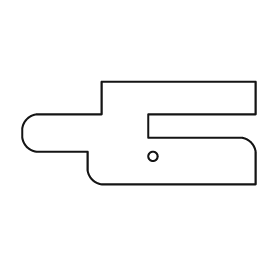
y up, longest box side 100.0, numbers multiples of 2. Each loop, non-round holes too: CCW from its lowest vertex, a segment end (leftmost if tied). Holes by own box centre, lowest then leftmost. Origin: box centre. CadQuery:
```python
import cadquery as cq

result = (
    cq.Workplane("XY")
    .moveTo(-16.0, -22.0)
    .lineTo(50.0, -22.0)
    .lineTo(50.0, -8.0)
    .threePointArc((48.0, -4.0), (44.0, -2.0))
    .lineTo(4.0, -2.0)
    .lineTo(4.0, 8.0)
    .lineTo(50.0, 8.0)
    .lineTo(50.0, 22.0)
    .lineTo(-16.0, 22.0)
    .lineTo(-16.0, 8.0)
    .lineTo(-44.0, 8.0)
    .threePointArc((-48.0, 6.0), (-50.0, 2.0))
    .lineTo(-50.0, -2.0)
    .threePointArc((-48.0, -6.0), (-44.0, -8.0))
    .lineTo(-22.0, -8.0)
    .lineTo(-22.0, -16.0)
    .threePointArc((-20.0, -20.0), (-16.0, -22.0))
    .close()
    .moveTo(6.0, -10.0)
    .circle(2.0)
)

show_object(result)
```